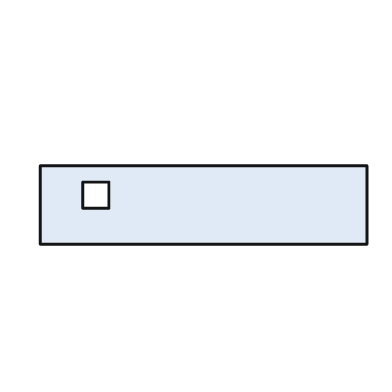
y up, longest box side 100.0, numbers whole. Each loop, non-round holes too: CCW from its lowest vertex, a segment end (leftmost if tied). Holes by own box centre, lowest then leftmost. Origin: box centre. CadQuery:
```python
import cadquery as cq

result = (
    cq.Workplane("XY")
    .moveTo(-50.0, -12.0)
    .lineTo(50.0, -12.0)
    .lineTo(50.0, 12.0)
    .lineTo(-50.0, 12.0)
    .close()
    .moveTo(-37.0, -1.0)
    .lineTo(-29.0, -1.0)
    .lineTo(-29.0, 7.0)
    .lineTo(-37.0, 7.0)
    .close()
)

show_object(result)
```